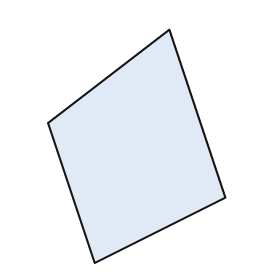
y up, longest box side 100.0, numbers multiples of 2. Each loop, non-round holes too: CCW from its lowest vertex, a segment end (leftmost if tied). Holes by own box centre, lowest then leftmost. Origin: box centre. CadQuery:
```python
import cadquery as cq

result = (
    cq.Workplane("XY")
    .moveTo(-18.0, -50.0)
    .lineTo(38.0, -22.0)
    .lineTo(14.0, 50.0)
    .lineTo(-38.0, 10.0)
    .close()
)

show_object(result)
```